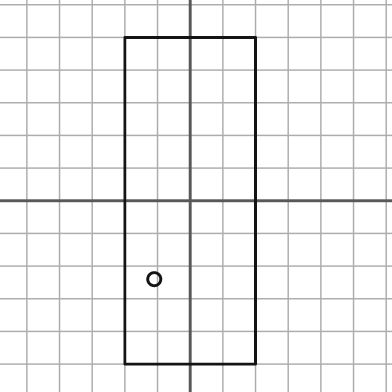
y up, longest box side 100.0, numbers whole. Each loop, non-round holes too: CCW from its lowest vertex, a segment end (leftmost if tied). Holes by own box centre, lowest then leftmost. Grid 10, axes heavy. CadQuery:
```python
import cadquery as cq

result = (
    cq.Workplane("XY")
    .moveTo(-20.0, -50.0)
    .lineTo(20.0, -50.0)
    .lineTo(20.0, 50.0)
    .lineTo(-20.0, 50.0)
    .close()
    .moveTo(-11.0, -24.0)
    .circle(2.0)
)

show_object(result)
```